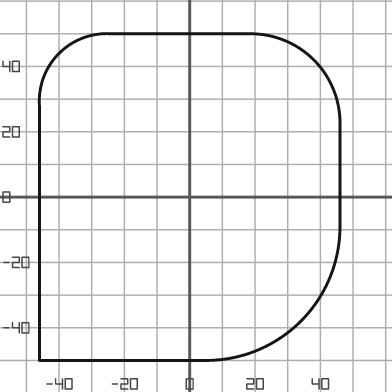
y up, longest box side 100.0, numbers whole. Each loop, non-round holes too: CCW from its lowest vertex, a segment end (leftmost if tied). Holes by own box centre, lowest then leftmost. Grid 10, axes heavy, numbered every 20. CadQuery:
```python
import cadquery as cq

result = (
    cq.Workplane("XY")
    .moveTo(-46.0, -50.0)
    .lineTo(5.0, -50.0)
    .threePointArc((34.0, -38.0), (46.0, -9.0))
    .lineTo(46.0, 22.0)
    .threePointArc((38.0, 42.0), (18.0, 50.0))
    .lineTo(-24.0, 50.0)
    .threePointArc((-40.0, 44.0), (-46.0, 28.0))
    .close()
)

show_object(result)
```